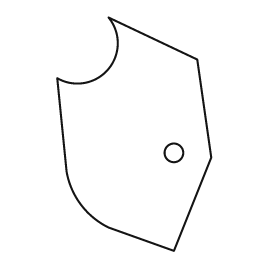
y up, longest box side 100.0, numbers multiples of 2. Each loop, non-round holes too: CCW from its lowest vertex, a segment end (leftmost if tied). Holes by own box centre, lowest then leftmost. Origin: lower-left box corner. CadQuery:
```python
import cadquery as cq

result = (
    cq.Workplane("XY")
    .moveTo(50.0, 0.0)
    .lineTo(66.0, 40.0)
    .lineTo(60.0, 82.0)
    .lineTo(22.0, 100.0)
    .threePointArc((22.0, 78.0), (0.0, 74.0))
    .lineTo(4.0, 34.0)
    .threePointArc((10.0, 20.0), (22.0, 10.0))
    .close()
    .moveTo(50.0, 42.0)
    .circle(4.0)
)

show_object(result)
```